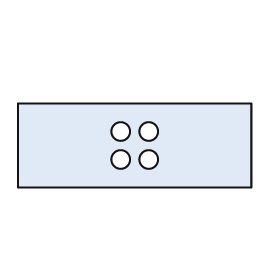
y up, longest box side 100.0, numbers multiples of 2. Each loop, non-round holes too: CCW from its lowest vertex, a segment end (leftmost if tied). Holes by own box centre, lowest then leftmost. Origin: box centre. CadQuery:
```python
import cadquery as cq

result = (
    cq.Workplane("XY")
    .moveTo(-50.0, -18.0)
    .lineTo(50.0, -18.0)
    .lineTo(50.0, 18.0)
    .lineTo(-50.0, 18.0)
    .close()
    .moveTo(-6.0, -6.0)
    .circle(4.0)
    .moveTo(6.0, -6.0)
    .circle(4.0)
    .moveTo(-6.0, 6.0)
    .circle(4.0)
    .moveTo(6.0, 6.0)
    .circle(4.0)
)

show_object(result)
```